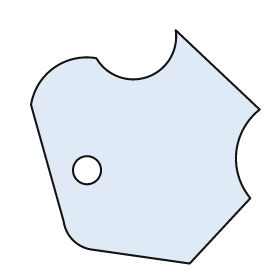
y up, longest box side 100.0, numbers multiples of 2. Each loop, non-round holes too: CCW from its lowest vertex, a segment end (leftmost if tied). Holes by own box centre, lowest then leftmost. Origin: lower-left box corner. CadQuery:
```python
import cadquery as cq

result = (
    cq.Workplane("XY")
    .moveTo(68.0, 0.0)
    .lineTo(94.0, 28.0)
    .threePointArc((88.0, 48.0), (98.0, 66.0))
    .lineTo(62.0, 100.0)
    .threePointArc((50.0, 80.0), (28.0, 88.0))
    .threePointArc((10.0, 84.0), (0.0, 68.0))
    .lineTo(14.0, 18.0)
    .threePointArc((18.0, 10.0), (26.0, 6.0))
    .close()
    .moveTo(24.0, 40.0)
    .circle(6.0)
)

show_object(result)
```